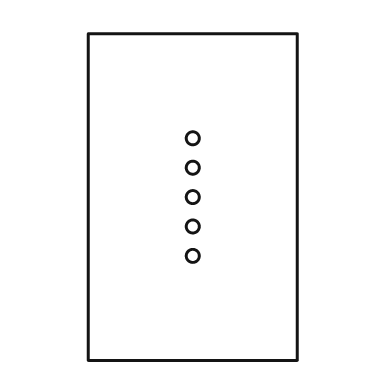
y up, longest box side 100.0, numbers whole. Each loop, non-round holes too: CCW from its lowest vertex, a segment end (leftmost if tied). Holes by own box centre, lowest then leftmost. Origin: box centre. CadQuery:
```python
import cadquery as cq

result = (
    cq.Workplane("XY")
    .moveTo(-32.0, -50.0)
    .lineTo(32.0, -50.0)
    .lineTo(32.0, 50.0)
    .lineTo(-32.0, 50.0)
    .close()
    .moveTo(0.0, -18.0)
    .circle(2.0)
    .moveTo(0.0, -9.0)
    .circle(2.0)
    .moveTo(0.0, 0.0)
    .circle(2.0)
    .moveTo(0.0, 9.0)
    .circle(2.0)
    .moveTo(0.0, 18.0)
    .circle(2.0)
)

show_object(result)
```